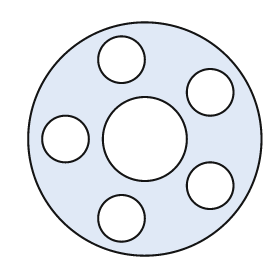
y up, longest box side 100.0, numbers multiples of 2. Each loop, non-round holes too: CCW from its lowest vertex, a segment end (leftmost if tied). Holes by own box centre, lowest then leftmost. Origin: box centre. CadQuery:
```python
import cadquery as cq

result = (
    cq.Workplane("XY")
    .moveTo(0.0, 0.0)
    .circle(50.0)
    .moveTo(-10.0, -34.0)
    .circle(10.0)
    .moveTo(28.0, -20.0)
    .circle(10.0)
    .moveTo(-34.0, 0.0)
    .circle(10.0)
    .moveTo(0.0, 0.0)
    .circle(18.0)
    .moveTo(28.0, 20.0)
    .circle(10.0)
    .moveTo(-10.0, 34.0)
    .circle(10.0)
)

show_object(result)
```